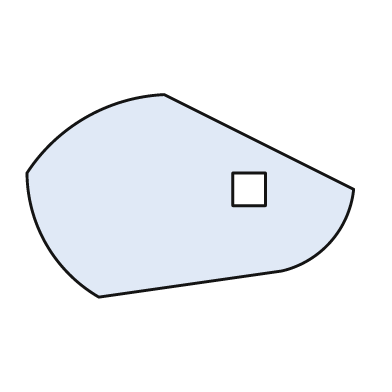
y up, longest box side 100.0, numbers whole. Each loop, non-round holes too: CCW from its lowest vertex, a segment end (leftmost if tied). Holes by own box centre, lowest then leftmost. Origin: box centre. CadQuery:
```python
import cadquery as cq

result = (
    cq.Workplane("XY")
    .moveTo(-28.0, -31.0)
    .lineTo(28.0, -23.0)
    .threePointArc((43.0, -14.0), (50.0, 2.0))
    .lineTo(-8.0, 31.0)
    .threePointArc((-32.0, 24.0), (-50.0, 7.0))
    .threePointArc((-44.0, -15.0), (-28.0, -31.0))
    .close()
    .moveTo(13.0, -3.0)
    .lineTo(23.0, -3.0)
    .lineTo(23.0, 7.0)
    .lineTo(13.0, 7.0)
    .close()
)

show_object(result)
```